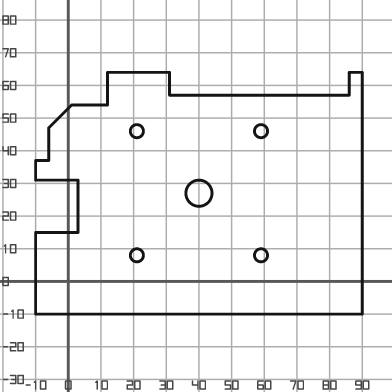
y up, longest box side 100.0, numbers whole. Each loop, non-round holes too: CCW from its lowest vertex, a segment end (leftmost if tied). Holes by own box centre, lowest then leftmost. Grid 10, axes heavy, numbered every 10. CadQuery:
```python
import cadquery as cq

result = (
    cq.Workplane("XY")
    .moveTo(-10.0, -10.0)
    .lineTo(90.0, -10.0)
    .lineTo(90.0, 64.0)
    .lineTo(86.0, 64.0)
    .lineTo(86.0, 57.0)
    .lineTo(31.0, 57.0)
    .lineTo(31.0, 64.0)
    .lineTo(12.0, 64.0)
    .lineTo(12.0, 54.0)
    .lineTo(1.0, 54.0)
    .lineTo(-6.0, 47.0)
    .lineTo(-6.0, 37.0)
    .lineTo(-10.0, 37.0)
    .lineTo(-10.0, 31.0)
    .lineTo(3.0, 31.0)
    .lineTo(3.0, 15.0)
    .lineTo(-10.0, 15.0)
    .close()
    .moveTo(21.0, 8.0)
    .circle(2.0)
    .moveTo(59.0, 8.0)
    .circle(2.0)
    .moveTo(40.0, 27.0)
    .circle(4.0)
    .moveTo(21.0, 46.0)
    .circle(2.0)
    .moveTo(59.0, 46.0)
    .circle(2.0)
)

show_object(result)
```